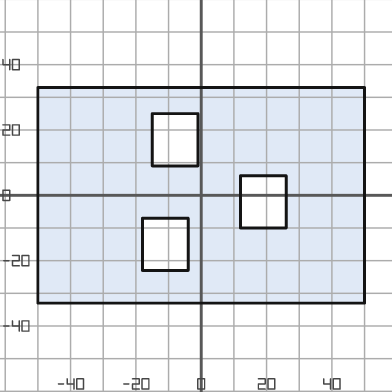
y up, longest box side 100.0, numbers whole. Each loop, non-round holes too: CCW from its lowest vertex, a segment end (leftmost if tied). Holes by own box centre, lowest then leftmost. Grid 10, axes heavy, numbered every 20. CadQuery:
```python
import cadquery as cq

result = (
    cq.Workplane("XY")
    .moveTo(-50.0, -33.0)
    .lineTo(50.0, -33.0)
    .lineTo(50.0, 33.0)
    .lineTo(-50.0, 33.0)
    .close()
    .moveTo(-18.0, -23.0)
    .lineTo(-4.0, -23.0)
    .lineTo(-4.0, -7.0)
    .lineTo(-18.0, -7.0)
    .close()
    .moveTo(12.0, -10.0)
    .lineTo(26.0, -10.0)
    .lineTo(26.0, 6.0)
    .lineTo(12.0, 6.0)
    .close()
    .moveTo(-15.0, 9.0)
    .lineTo(-1.0, 9.0)
    .lineTo(-1.0, 25.0)
    .lineTo(-15.0, 25.0)
    .close()
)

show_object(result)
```